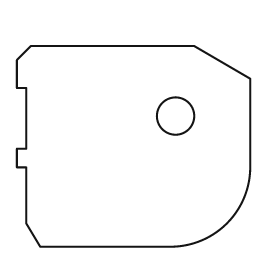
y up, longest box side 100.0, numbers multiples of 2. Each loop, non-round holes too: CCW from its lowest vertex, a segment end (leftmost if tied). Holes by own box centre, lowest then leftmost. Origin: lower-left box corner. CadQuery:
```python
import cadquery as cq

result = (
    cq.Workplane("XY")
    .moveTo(10.0, 0.0)
    .lineTo(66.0, 0.0)
    .threePointArc((90.0, 10.0), (100.0, 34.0))
    .lineTo(100.0, 72.0)
    .lineTo(76.0, 86.0)
    .lineTo(6.0, 86.0)
    .lineTo(0.0, 80.0)
    .lineTo(0.0, 68.0)
    .lineTo(4.0, 68.0)
    .lineTo(4.0, 42.0)
    .lineTo(0.0, 42.0)
    .lineTo(0.0, 34.0)
    .lineTo(4.0, 34.0)
    .lineTo(4.0, 10.0)
    .close()
    .moveTo(68.0, 56.0)
    .circle(8.0)
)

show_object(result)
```